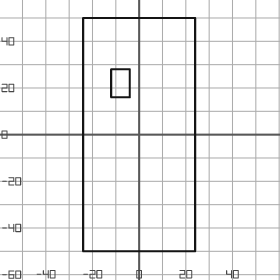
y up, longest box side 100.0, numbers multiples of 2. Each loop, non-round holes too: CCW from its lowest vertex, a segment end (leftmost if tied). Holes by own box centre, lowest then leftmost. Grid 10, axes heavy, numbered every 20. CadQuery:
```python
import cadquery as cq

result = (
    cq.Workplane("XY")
    .moveTo(-24.0, -50.0)
    .lineTo(24.0, -50.0)
    .lineTo(24.0, 50.0)
    .lineTo(-24.0, 50.0)
    .close()
    .moveTo(-12.0, 16.0)
    .lineTo(-4.0, 16.0)
    .lineTo(-4.0, 28.0)
    .lineTo(-12.0, 28.0)
    .close()
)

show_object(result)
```